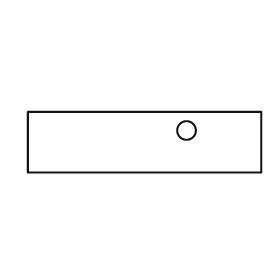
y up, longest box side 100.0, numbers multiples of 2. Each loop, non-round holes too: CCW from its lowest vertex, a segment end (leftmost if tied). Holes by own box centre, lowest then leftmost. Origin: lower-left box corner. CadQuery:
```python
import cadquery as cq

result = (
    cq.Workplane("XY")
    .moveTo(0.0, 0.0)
    .lineTo(100.0, 0.0)
    .lineTo(100.0, 26.0)
    .lineTo(0.0, 26.0)
    .close()
    .moveTo(68.0, 18.0)
    .circle(4.0)
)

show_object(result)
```